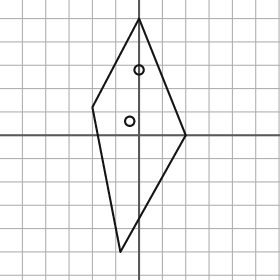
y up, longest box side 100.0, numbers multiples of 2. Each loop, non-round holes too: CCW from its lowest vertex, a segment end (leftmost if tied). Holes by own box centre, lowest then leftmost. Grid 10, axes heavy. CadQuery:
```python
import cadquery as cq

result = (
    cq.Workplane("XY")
    .moveTo(-8.0, -50.0)
    .lineTo(20.0, 0.0)
    .lineTo(0.0, 50.0)
    .lineTo(-20.0, 12.0)
    .close()
    .moveTo(-4.0, 6.0)
    .circle(2.0)
    .moveTo(0.0, 28.0)
    .circle(2.0)
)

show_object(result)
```